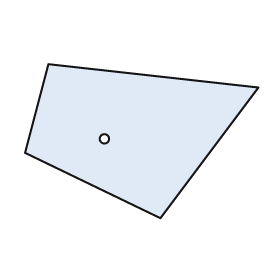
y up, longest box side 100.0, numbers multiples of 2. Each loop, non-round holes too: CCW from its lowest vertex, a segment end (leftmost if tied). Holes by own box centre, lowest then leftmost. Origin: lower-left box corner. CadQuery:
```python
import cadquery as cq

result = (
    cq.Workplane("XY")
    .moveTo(58.0, 0.0)
    .lineTo(100.0, 56.0)
    .lineTo(10.0, 66.0)
    .lineTo(0.0, 28.0)
    .close()
    .moveTo(34.0, 34.0)
    .circle(2.0)
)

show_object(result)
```